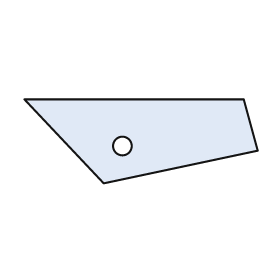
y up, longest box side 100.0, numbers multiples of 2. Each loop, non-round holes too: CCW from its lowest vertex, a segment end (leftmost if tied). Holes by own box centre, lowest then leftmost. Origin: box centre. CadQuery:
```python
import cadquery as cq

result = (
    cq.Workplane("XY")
    .moveTo(-16.0, -18.0)
    .lineTo(50.0, -4.0)
    .lineTo(44.0, 18.0)
    .lineTo(-50.0, 18.0)
    .close()
    .moveTo(-8.0, -2.0)
    .circle(4.0)
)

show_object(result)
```